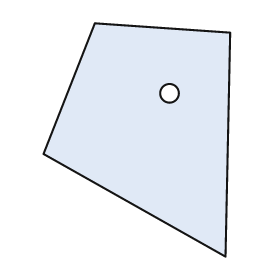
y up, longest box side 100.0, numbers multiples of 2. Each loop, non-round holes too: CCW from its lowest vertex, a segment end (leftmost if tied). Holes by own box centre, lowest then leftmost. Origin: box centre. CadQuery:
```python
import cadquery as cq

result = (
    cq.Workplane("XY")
    .moveTo(38.0, -50.0)
    .lineTo(40.0, 46.0)
    .lineTo(-18.0, 50.0)
    .lineTo(-40.0, -6.0)
    .close()
    .moveTo(14.0, 20.0)
    .circle(4.0)
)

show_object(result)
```